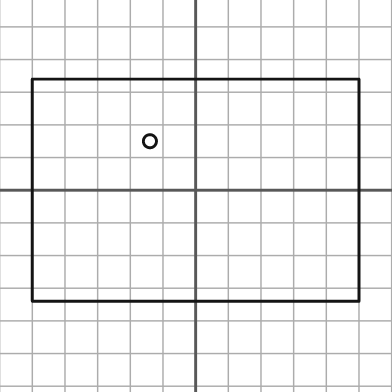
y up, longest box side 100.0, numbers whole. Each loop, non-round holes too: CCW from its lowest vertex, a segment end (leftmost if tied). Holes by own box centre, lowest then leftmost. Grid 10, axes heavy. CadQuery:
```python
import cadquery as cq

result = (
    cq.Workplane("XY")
    .moveTo(-50.0, -34.0)
    .lineTo(50.0, -34.0)
    .lineTo(50.0, 34.0)
    .lineTo(-50.0, 34.0)
    .close()
    .moveTo(-14.0, 15.0)
    .circle(2.0)
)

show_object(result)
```